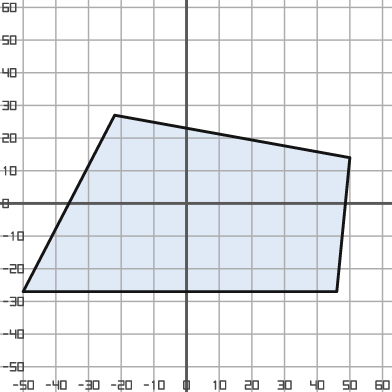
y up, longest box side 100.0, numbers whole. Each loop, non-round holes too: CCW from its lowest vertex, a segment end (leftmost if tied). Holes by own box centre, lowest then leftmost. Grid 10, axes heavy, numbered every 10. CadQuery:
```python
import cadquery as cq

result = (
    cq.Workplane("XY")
    .moveTo(-50.0, -27.0)
    .lineTo(46.0, -27.0)
    .lineTo(50.0, 14.0)
    .lineTo(-22.0, 27.0)
    .close()
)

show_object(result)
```